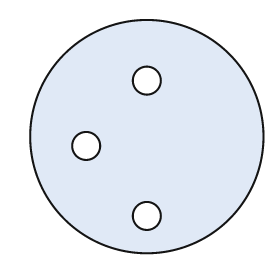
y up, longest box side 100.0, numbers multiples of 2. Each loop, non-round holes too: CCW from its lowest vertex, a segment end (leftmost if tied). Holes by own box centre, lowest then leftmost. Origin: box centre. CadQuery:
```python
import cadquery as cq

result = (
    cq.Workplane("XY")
    .moveTo(0.0, 0.0)
    .circle(50.0)
    .moveTo(0.0, -34.0)
    .circle(6.0)
    .moveTo(-26.0, -4.0)
    .circle(6.0)
    .moveTo(0.0, 24.0)
    .circle(6.0)
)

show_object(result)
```